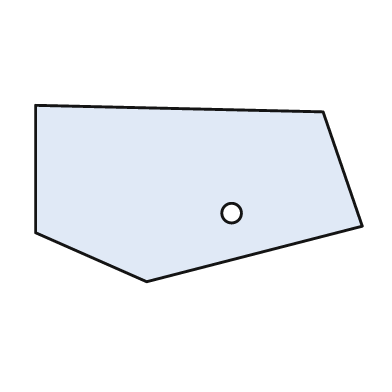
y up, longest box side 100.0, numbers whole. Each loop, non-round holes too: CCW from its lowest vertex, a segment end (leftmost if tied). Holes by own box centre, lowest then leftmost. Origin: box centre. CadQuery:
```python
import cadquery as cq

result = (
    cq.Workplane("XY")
    .moveTo(-16.0, -27.0)
    .lineTo(50.0, -10.0)
    .lineTo(38.0, 25.0)
    .lineTo(-50.0, 27.0)
    .lineTo(-50.0, -12.0)
    .close()
    .moveTo(10.0, -6.0)
    .circle(3.0)
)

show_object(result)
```